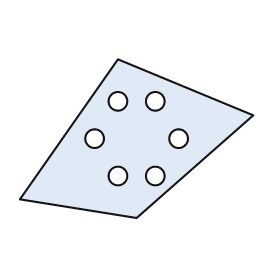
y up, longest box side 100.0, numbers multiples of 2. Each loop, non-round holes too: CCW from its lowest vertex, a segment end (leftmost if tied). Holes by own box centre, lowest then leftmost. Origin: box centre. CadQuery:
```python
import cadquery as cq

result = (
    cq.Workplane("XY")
    .moveTo(0.0, -34.0)
    .lineTo(50.0, 10.0)
    .lineTo(-8.0, 34.0)
    .lineTo(-50.0, -26.0)
    .close()
    .moveTo(-8.0, -16.0)
    .circle(4.0)
    .moveTo(8.0, -16.0)
    .circle(4.0)
    .moveTo(-18.0, 0.0)
    .circle(4.0)
    .moveTo(18.0, 0.0)
    .circle(4.0)
    .moveTo(-8.0, 16.0)
    .circle(4.0)
    .moveTo(8.0, 16.0)
    .circle(4.0)
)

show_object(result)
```